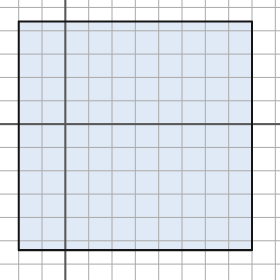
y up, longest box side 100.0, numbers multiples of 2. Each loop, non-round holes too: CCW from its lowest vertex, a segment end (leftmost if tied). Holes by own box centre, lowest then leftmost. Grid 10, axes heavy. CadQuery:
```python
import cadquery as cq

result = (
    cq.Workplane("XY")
    .moveTo(-20.0, -54.0)
    .lineTo(80.0, -54.0)
    .lineTo(80.0, 44.0)
    .lineTo(-20.0, 44.0)
    .close()
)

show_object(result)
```